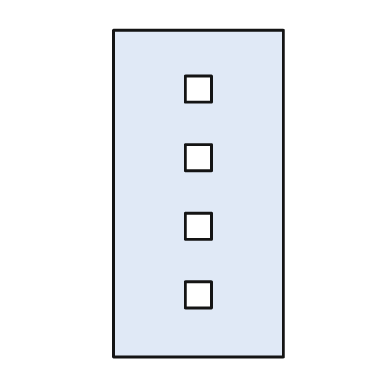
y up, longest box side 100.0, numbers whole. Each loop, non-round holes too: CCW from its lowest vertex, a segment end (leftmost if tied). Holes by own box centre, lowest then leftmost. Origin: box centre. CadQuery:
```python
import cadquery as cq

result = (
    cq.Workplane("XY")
    .moveTo(-26.0, -50.0)
    .lineTo(26.0, -50.0)
    .lineTo(26.0, 50.0)
    .lineTo(-26.0, 50.0)
    .close()
    .moveTo(-4.0, -35.0)
    .lineTo(4.0, -35.0)
    .lineTo(4.0, -27.0)
    .lineTo(-4.0, -27.0)
    .close()
    .moveTo(-4.0, -14.0)
    .lineTo(4.0, -14.0)
    .lineTo(4.0, -6.0)
    .lineTo(-4.0, -6.0)
    .close()
    .moveTo(-4.0, 7.0)
    .lineTo(4.0, 7.0)
    .lineTo(4.0, 15.0)
    .lineTo(-4.0, 15.0)
    .close()
    .moveTo(-4.0, 28.0)
    .lineTo(4.0, 28.0)
    .lineTo(4.0, 36.0)
    .lineTo(-4.0, 36.0)
    .close()
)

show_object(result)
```